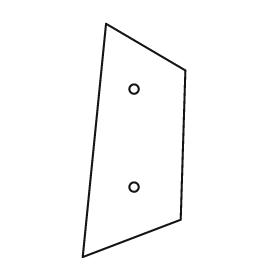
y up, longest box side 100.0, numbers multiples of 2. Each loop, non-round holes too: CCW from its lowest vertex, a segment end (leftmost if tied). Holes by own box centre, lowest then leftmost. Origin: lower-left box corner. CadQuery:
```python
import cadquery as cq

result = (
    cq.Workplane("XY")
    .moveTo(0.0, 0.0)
    .lineTo(42.0, 16.0)
    .lineTo(44.0, 80.0)
    .lineTo(10.0, 100.0)
    .close()
    .moveTo(22.0, 30.0)
    .circle(2.0)
    .moveTo(22.0, 72.0)
    .circle(2.0)
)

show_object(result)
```